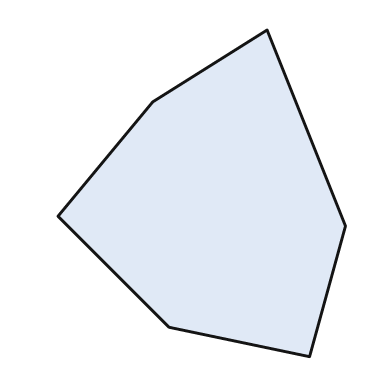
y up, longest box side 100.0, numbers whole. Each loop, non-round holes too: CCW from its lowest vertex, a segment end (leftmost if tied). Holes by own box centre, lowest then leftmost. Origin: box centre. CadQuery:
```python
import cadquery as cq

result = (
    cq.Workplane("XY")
    .moveTo(33.0, -50.0)
    .lineTo(44.0, -10.0)
    .lineTo(20.0, 50.0)
    .lineTo(-15.0, 28.0)
    .lineTo(-44.0, -7.0)
    .lineTo(-10.0, -41.0)
    .close()
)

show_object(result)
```